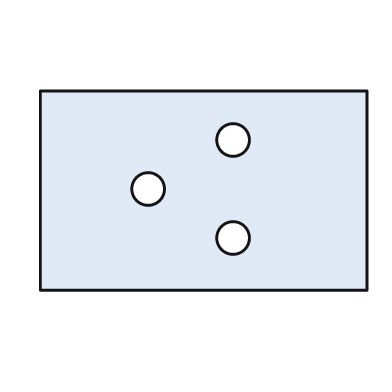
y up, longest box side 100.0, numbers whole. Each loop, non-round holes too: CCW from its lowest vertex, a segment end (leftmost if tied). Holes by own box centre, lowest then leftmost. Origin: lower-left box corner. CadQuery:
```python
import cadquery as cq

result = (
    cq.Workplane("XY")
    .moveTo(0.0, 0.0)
    .lineTo(100.0, 0.0)
    .lineTo(100.0, 61.0)
    .lineTo(0.0, 61.0)
    .close()
    .moveTo(59.0, 16.0)
    .circle(5.0)
    .moveTo(33.0, 31.0)
    .circle(5.0)
    .moveTo(59.0, 46.0)
    .circle(5.0)
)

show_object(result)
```